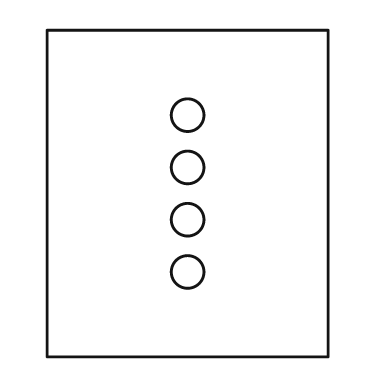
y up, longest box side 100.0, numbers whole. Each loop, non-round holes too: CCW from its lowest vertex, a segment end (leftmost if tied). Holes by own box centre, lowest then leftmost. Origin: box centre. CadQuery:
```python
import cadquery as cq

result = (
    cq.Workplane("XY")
    .moveTo(-43.0, -50.0)
    .lineTo(43.0, -50.0)
    .lineTo(43.0, 50.0)
    .lineTo(-43.0, 50.0)
    .close()
    .moveTo(0.0, -24.0)
    .circle(5.0)
    .moveTo(0.0, -8.0)
    .circle(5.0)
    .moveTo(0.0, 8.0)
    .circle(5.0)
    .moveTo(0.0, 24.0)
    .circle(5.0)
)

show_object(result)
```